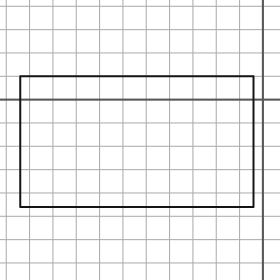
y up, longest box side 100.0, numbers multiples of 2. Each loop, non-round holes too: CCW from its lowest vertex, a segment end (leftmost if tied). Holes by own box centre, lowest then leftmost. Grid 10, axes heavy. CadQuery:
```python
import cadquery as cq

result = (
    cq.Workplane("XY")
    .moveTo(-104.0, -46.0)
    .lineTo(-4.0, -46.0)
    .lineTo(-4.0, 10.0)
    .lineTo(-104.0, 10.0)
    .close()
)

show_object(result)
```